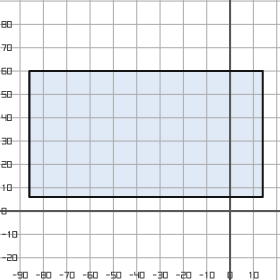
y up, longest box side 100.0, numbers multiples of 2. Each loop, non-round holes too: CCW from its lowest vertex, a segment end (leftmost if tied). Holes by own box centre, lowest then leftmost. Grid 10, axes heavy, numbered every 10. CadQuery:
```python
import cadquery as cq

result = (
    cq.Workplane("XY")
    .moveTo(-86.0, 6.0)
    .lineTo(14.0, 6.0)
    .lineTo(14.0, 60.0)
    .lineTo(-86.0, 60.0)
    .close()
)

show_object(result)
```